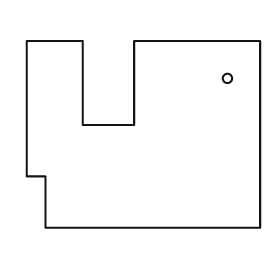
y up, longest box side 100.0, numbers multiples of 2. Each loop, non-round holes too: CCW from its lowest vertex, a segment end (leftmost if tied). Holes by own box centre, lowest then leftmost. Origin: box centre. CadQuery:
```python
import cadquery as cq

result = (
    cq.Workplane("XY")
    .moveTo(-42.0, -40.0)
    .lineTo(50.0, -40.0)
    .lineTo(50.0, 40.0)
    .lineTo(-4.0, 40.0)
    .lineTo(-4.0, 4.0)
    .lineTo(-26.0, 4.0)
    .lineTo(-26.0, 40.0)
    .lineTo(-50.0, 40.0)
    .lineTo(-50.0, -18.0)
    .lineTo(-42.0, -18.0)
    .close()
    .moveTo(36.0, 24.0)
    .circle(2.0)
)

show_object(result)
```